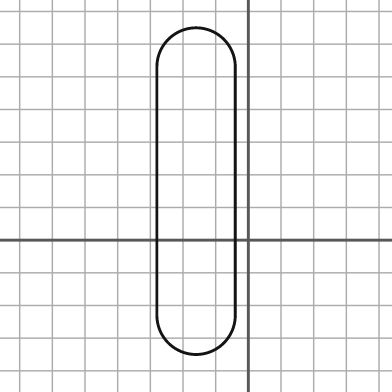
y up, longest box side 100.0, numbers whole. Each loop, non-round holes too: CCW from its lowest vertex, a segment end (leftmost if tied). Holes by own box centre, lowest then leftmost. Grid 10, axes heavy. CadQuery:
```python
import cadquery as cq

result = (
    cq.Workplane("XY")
    .moveTo(-28.0, -23.0)
    .threePointArc((-16.0, -35.0), (-4.0, -23.0))
    .lineTo(-4.0, 53.0)
    .threePointArc((-16.0, 65.0), (-28.0, 53.0))
    .close()
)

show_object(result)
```